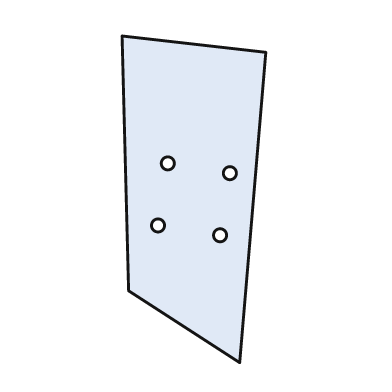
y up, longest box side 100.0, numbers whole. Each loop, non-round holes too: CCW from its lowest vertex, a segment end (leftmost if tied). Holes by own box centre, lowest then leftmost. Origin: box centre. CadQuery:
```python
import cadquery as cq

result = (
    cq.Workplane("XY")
    .moveTo(14.0, -50.0)
    .lineTo(22.0, 45.0)
    .lineTo(-22.0, 50.0)
    .lineTo(-20.0, -28.0)
    .close()
    .moveTo(8.0, -11.0)
    .circle(2.0)
    .moveTo(-11.0, -8.0)
    .circle(2.0)
    .moveTo(11.0, 8.0)
    .circle(2.0)
    .moveTo(-8.0, 11.0)
    .circle(2.0)
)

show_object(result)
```